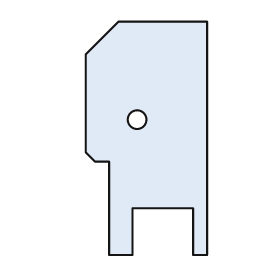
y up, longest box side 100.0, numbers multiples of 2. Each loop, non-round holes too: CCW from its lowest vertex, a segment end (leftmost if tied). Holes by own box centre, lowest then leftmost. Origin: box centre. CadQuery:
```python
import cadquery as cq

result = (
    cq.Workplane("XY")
    .moveTo(-16.0, -50.0)
    .lineTo(-6.0, -50.0)
    .lineTo(-6.0, -30.0)
    .lineTo(20.0, -30.0)
    .lineTo(20.0, -50.0)
    .lineTo(26.0, -50.0)
    .lineTo(26.0, 50.0)
    .lineTo(-12.0, 50.0)
    .lineTo(-26.0, 36.0)
    .lineTo(-26.0, -6.0)
    .lineTo(-22.0, -10.0)
    .lineTo(-16.0, -10.0)
    .close()
    .moveTo(-4.0, 8.0)
    .circle(4.0)
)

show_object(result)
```